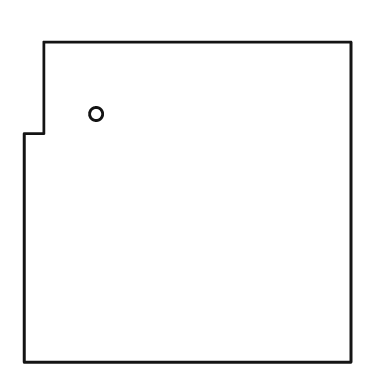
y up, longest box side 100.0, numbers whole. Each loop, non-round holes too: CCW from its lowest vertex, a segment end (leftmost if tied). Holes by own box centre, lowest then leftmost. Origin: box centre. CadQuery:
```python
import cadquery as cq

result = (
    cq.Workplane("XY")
    .moveTo(-50.0, -49.0)
    .lineTo(50.0, -49.0)
    .lineTo(50.0, 49.0)
    .lineTo(-44.0, 49.0)
    .lineTo(-44.0, 21.0)
    .lineTo(-50.0, 21.0)
    .close()
    .moveTo(-28.0, 27.0)
    .circle(2.0)
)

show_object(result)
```